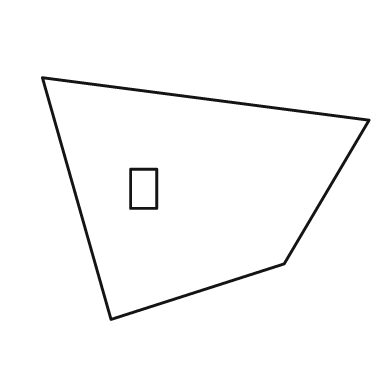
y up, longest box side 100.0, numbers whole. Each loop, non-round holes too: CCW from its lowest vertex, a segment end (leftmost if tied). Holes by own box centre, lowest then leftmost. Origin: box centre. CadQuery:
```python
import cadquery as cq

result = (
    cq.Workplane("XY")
    .moveTo(-29.0, -37.0)
    .lineTo(24.0, -20.0)
    .lineTo(50.0, 24.0)
    .lineTo(-50.0, 37.0)
    .close()
    .moveTo(-23.0, -3.0)
    .lineTo(-15.0, -3.0)
    .lineTo(-15.0, 9.0)
    .lineTo(-23.0, 9.0)
    .close()
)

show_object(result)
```